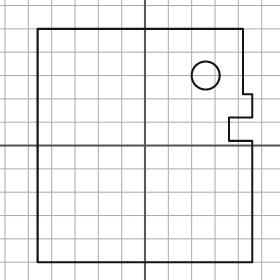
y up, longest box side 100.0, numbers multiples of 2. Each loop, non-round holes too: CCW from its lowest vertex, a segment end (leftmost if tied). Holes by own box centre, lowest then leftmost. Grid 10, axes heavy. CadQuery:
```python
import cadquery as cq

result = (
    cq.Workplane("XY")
    .moveTo(-46.0, -50.0)
    .lineTo(46.0, -50.0)
    .lineTo(46.0, 2.0)
    .lineTo(36.0, 2.0)
    .lineTo(36.0, 12.0)
    .lineTo(46.0, 12.0)
    .lineTo(46.0, 22.0)
    .lineTo(42.0, 22.0)
    .lineTo(42.0, 50.0)
    .lineTo(-46.0, 50.0)
    .close()
    .moveTo(26.0, 30.0)
    .circle(6.0)
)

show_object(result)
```